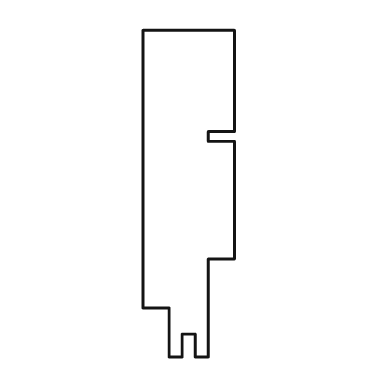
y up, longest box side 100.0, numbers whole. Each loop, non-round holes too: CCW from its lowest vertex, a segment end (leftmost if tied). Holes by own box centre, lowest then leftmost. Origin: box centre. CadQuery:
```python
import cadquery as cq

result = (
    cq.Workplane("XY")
    .moveTo(-6.0, -50.0)
    .lineTo(-2.0, -50.0)
    .lineTo(-2.0, -43.0)
    .lineTo(2.0, -43.0)
    .lineTo(2.0, -50.0)
    .lineTo(6.0, -50.0)
    .lineTo(6.0, -20.0)
    .lineTo(14.0, -20.0)
    .lineTo(14.0, 16.0)
    .lineTo(6.0, 16.0)
    .lineTo(6.0, 19.0)
    .lineTo(14.0, 19.0)
    .lineTo(14.0, 50.0)
    .lineTo(-14.0, 50.0)
    .lineTo(-14.0, -35.0)
    .lineTo(-6.0, -35.0)
    .close()
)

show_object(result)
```